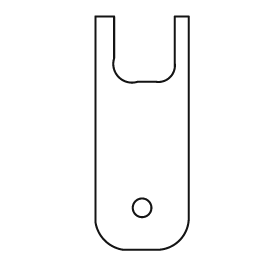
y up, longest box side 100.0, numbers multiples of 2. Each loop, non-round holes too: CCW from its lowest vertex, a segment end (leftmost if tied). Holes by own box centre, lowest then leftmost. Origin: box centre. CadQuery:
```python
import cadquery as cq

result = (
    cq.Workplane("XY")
    .moveTo(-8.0, -50.0)
    .lineTo(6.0, -50.0)
    .threePointArc((16.0, -46.0), (20.0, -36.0))
    .lineTo(20.0, 50.0)
    .lineTo(14.0, 50.0)
    .lineTo(14.0, 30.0)
    .threePointArc((12.0, 24.0), (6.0, 22.0))
    .lineTo(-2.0, 22.0)
    .threePointArc((-10.0, 24.0), (-12.0, 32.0))
    .lineTo(-12.0, 50.0)
    .lineTo(-20.0, 50.0)
    .lineTo(-20.0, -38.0)
    .threePointArc((-16.0, -46.0), (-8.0, -50.0))
    .close()
    .moveTo(0.0, -32.0)
    .circle(4.0)
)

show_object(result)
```